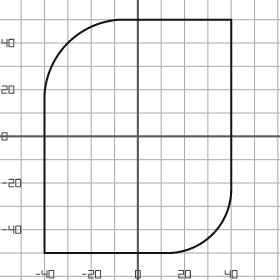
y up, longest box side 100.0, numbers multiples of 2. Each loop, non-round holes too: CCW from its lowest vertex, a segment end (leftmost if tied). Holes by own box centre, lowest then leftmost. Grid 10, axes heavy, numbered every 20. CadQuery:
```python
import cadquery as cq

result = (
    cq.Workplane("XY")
    .moveTo(-40.0, -50.0)
    .lineTo(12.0, -50.0)
    .threePointArc((32.0, -42.0), (40.0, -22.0))
    .lineTo(40.0, 50.0)
    .lineTo(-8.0, 50.0)
    .threePointArc((-30.0, 40.0), (-40.0, 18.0))
    .close()
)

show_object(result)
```